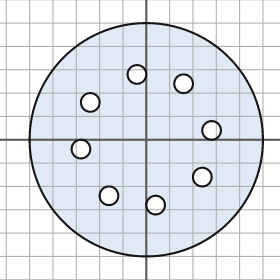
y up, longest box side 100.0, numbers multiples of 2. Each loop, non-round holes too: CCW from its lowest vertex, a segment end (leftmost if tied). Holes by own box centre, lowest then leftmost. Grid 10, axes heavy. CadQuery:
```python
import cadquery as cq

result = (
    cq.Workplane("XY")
    .moveTo(0.0, 0.0)
    .circle(50.0)
    .moveTo(4.0, -28.0)
    .circle(4.0)
    .moveTo(-16.0, -24.0)
    .circle(4.0)
    .moveTo(24.0, -16.0)
    .circle(4.0)
    .moveTo(-28.0, -4.0)
    .circle(4.0)
    .moveTo(28.0, 4.0)
    .circle(4.0)
    .moveTo(-24.0, 16.0)
    .circle(4.0)
    .moveTo(16.0, 24.0)
    .circle(4.0)
    .moveTo(-4.0, 28.0)
    .circle(4.0)
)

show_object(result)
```